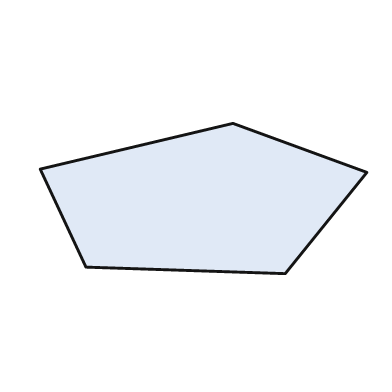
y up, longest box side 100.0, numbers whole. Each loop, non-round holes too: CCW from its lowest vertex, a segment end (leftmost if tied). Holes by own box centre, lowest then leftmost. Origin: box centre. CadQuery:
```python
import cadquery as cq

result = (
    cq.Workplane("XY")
    .moveTo(25.0, -23.0)
    .lineTo(50.0, 8.0)
    .lineTo(9.0, 23.0)
    .lineTo(-50.0, 9.0)
    .lineTo(-36.0, -21.0)
    .close()
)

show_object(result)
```